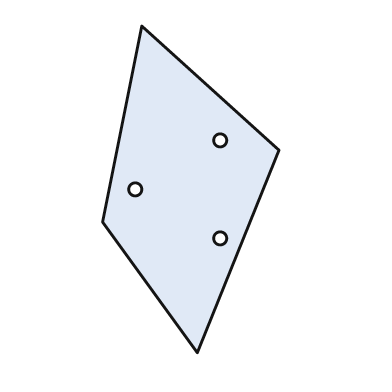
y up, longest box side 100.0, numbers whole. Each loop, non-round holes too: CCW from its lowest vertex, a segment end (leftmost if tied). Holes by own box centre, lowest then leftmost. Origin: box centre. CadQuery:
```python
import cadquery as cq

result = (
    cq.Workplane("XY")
    .moveTo(2.0, -50.0)
    .lineTo(27.0, 12.0)
    .lineTo(-15.0, 50.0)
    .lineTo(-27.0, -10.0)
    .close()
    .moveTo(9.0, -15.0)
    .circle(2.0)
    .moveTo(-17.0, 0.0)
    .circle(2.0)
    .moveTo(9.0, 15.0)
    .circle(2.0)
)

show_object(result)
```